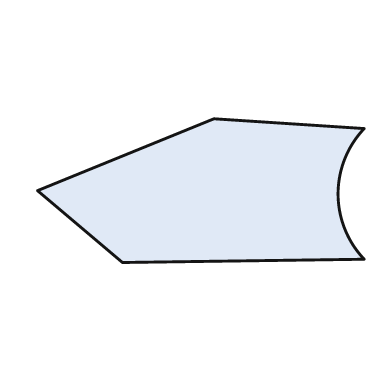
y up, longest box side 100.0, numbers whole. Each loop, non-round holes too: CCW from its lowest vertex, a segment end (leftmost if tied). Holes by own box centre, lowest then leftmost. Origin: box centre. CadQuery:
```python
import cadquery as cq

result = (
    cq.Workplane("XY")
    .moveTo(-24.0, -22.0)
    .lineTo(50.0, -21.0)
    .threePointArc((42.0, -1.0), (50.0, 19.0))
    .lineTo(4.0, 22.0)
    .lineTo(-50.0, 0.0)
    .close()
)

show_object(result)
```